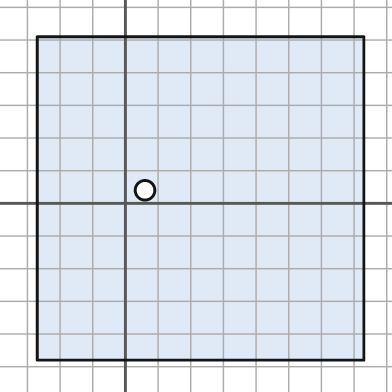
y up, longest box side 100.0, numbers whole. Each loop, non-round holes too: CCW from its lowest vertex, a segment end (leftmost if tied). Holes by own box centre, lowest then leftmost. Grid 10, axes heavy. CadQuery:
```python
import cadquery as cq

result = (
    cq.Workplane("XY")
    .moveTo(-27.0, -48.0)
    .lineTo(73.0, -48.0)
    .lineTo(73.0, 51.0)
    .lineTo(-27.0, 51.0)
    .close()
    .moveTo(6.0, 4.0)
    .circle(3.0)
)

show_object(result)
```